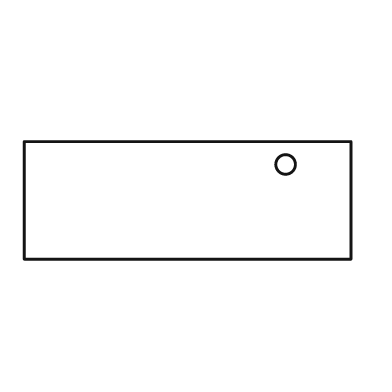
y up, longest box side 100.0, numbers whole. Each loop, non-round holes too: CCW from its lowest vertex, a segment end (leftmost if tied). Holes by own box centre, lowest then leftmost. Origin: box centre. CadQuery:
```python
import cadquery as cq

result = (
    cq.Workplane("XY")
    .moveTo(-50.0, -18.0)
    .lineTo(50.0, -18.0)
    .lineTo(50.0, 18.0)
    .lineTo(-50.0, 18.0)
    .close()
    .moveTo(30.0, 11.0)
    .circle(3.0)
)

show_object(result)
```